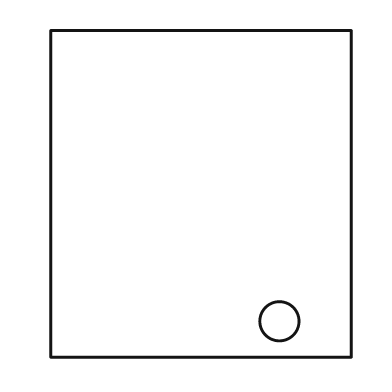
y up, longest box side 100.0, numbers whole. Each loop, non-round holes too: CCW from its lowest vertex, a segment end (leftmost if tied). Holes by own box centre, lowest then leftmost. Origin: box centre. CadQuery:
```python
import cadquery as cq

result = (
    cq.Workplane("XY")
    .moveTo(-46.0, -50.0)
    .lineTo(46.0, -50.0)
    .lineTo(46.0, 50.0)
    .lineTo(-46.0, 50.0)
    .close()
    .moveTo(24.0, -39.0)
    .circle(6.0)
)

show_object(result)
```